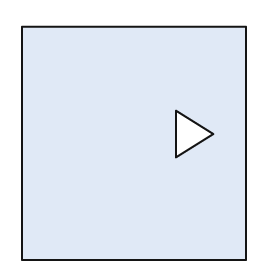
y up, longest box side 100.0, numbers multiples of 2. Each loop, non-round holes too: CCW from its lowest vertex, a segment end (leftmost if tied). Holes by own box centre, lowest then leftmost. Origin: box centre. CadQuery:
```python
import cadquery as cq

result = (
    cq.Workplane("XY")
    .moveTo(-48.0, -50.0)
    .lineTo(48.0, -50.0)
    .lineTo(48.0, 50.0)
    .lineTo(-48.0, 50.0)
    .close()
    .moveTo(18.0, -6.0)
    .lineTo(34.0, 4.0)
    .lineTo(18.0, 14.0)
    .close()
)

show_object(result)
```